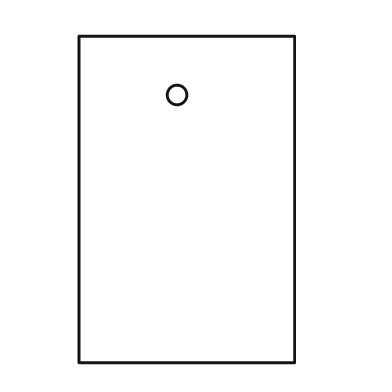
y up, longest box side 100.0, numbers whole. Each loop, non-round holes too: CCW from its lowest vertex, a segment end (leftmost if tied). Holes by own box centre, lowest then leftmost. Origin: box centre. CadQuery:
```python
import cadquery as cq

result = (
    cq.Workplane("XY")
    .moveTo(-33.0, -50.0)
    .lineTo(33.0, -50.0)
    .lineTo(33.0, 50.0)
    .lineTo(-33.0, 50.0)
    .close()
    .moveTo(-3.0, 32.0)
    .circle(3.0)
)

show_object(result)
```